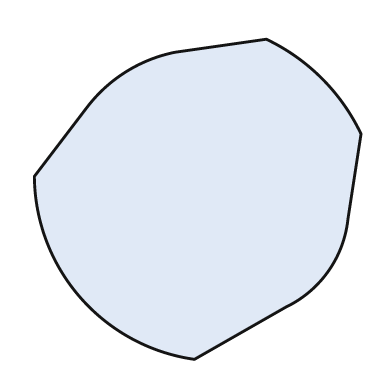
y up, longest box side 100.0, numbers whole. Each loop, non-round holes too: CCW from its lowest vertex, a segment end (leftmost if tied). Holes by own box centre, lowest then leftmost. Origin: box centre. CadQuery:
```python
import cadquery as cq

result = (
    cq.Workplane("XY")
    .moveTo(-1.0, -49.0)
    .lineTo(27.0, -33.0)
    .threePointArc((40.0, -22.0), (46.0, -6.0))
    .lineTo(50.0, 20.0)
    .threePointArc((38.0, 37.0), (21.0, 49.0))
    .lineTo(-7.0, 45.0)
    .threePointArc((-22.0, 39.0), (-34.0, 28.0))
    .lineTo(-50.0, 7.0)
    .threePointArc((-36.0, -30.0), (-1.0, -49.0))
    .close()
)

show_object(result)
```